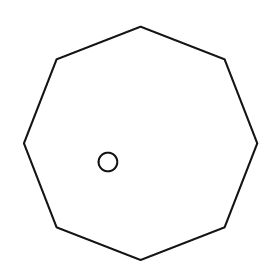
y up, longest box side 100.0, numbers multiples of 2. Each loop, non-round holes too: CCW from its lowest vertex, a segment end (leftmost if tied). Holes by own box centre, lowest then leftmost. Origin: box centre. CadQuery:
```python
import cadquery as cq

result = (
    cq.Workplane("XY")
    .moveTo(0.0, -50.0)
    .lineTo(36.0, -36.0)
    .lineTo(50.0, 0.0)
    .lineTo(36.0, 36.0)
    .lineTo(0.0, 50.0)
    .lineTo(-36.0, 36.0)
    .lineTo(-50.0, 0.0)
    .lineTo(-36.0, -36.0)
    .close()
    .moveTo(-14.0, -8.0)
    .circle(4.0)
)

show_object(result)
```